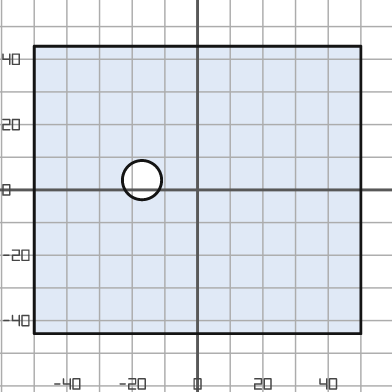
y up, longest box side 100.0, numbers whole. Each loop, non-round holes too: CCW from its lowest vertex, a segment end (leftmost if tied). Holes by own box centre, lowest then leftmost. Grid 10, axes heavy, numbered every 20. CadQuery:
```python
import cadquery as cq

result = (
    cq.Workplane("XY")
    .moveTo(-50.0, -44.0)
    .lineTo(50.0, -44.0)
    .lineTo(50.0, 44.0)
    .lineTo(-50.0, 44.0)
    .close()
    .moveTo(-17.0, 3.0)
    .circle(6.0)
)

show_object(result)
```